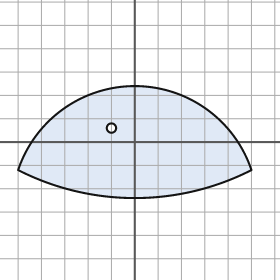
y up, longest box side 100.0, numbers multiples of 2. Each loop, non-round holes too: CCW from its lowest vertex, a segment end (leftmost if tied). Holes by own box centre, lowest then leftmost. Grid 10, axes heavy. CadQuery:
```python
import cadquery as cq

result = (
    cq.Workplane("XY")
    .moveTo(-50.0, -12.0)
    .threePointArc((0.0, -24.0), (50.0, -12.0))
    .threePointArc((0.0, 24.0), (-50.0, -12.0))
    .close()
    .moveTo(-10.0, 6.0)
    .circle(2.0)
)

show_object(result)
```